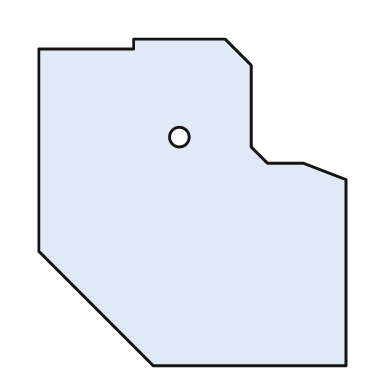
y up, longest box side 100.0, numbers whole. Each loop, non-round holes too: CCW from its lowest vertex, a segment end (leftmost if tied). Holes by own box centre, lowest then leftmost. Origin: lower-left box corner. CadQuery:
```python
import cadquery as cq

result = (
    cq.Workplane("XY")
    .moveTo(35.0, 0.0)
    .lineTo(94.0, 0.0)
    .lineTo(94.0, 57.0)
    .lineTo(81.0, 62.0)
    .lineTo(70.0, 62.0)
    .lineTo(65.0, 67.0)
    .lineTo(65.0, 92.0)
    .lineTo(57.0, 100.0)
    .lineTo(29.0, 100.0)
    .lineTo(29.0, 97.0)
    .lineTo(0.0, 97.0)
    .lineTo(0.0, 35.0)
    .close()
    .moveTo(43.0, 70.0)
    .circle(3.0)
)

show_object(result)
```